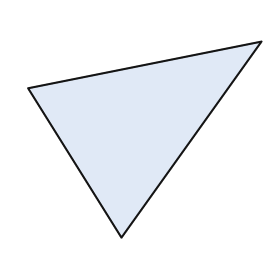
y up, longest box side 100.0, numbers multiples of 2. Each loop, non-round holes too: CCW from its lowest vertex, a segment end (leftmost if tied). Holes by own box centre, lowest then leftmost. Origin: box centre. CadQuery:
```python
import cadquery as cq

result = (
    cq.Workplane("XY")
    .moveTo(-10.0, -42.0)
    .lineTo(50.0, 42.0)
    .lineTo(-50.0, 22.0)
    .close()
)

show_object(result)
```